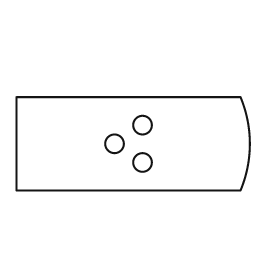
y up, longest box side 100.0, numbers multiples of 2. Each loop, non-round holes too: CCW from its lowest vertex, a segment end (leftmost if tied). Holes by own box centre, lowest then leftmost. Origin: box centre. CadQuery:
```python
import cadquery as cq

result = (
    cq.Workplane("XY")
    .moveTo(-50.0, -20.0)
    .lineTo(46.0, -20.0)
    .threePointArc((50.0, 0.0), (46.0, 20.0))
    .lineTo(-50.0, 20.0)
    .close()
    .moveTo(4.0, -8.0)
    .circle(4.0)
    .moveTo(-8.0, 0.0)
    .circle(4.0)
    .moveTo(4.0, 8.0)
    .circle(4.0)
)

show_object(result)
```